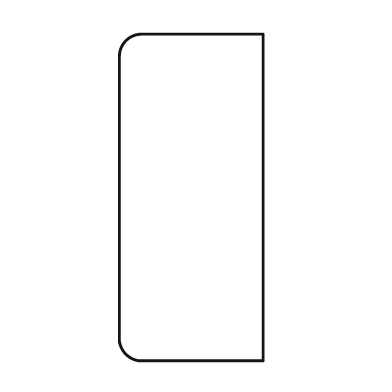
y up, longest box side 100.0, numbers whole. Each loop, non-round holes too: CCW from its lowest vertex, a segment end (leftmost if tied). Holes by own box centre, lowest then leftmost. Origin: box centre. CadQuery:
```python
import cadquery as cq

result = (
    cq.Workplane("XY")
    .moveTo(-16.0, -50.0)
    .lineTo(22.0, -50.0)
    .lineTo(22.0, 50.0)
    .lineTo(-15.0, 50.0)
    .threePointArc((-20.0, 48.0), (-22.0, 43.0))
    .lineTo(-22.0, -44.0)
    .threePointArc((-20.0, -48.0), (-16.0, -50.0))
    .close()
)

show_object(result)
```